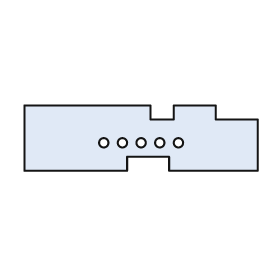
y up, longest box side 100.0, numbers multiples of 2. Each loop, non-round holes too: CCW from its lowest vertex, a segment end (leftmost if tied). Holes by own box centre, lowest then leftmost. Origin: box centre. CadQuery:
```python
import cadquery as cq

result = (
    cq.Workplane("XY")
    .moveTo(-50.0, -14.0)
    .lineTo(-6.0, -14.0)
    .lineTo(-6.0, -8.0)
    .lineTo(12.0, -8.0)
    .lineTo(12.0, -14.0)
    .lineTo(50.0, -14.0)
    .lineTo(50.0, 8.0)
    .lineTo(32.0, 8.0)
    .lineTo(32.0, 14.0)
    .lineTo(14.0, 14.0)
    .lineTo(14.0, 8.0)
    .lineTo(4.0, 8.0)
    .lineTo(4.0, 14.0)
    .lineTo(-50.0, 14.0)
    .close()
    .moveTo(-16.0, -2.0)
    .circle(2.0)
    .moveTo(-8.0, -2.0)
    .circle(2.0)
    .moveTo(0.0, -2.0)
    .circle(2.0)
    .moveTo(8.0, -2.0)
    .circle(2.0)
    .moveTo(16.0, -2.0)
    .circle(2.0)
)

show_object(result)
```